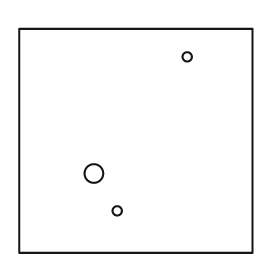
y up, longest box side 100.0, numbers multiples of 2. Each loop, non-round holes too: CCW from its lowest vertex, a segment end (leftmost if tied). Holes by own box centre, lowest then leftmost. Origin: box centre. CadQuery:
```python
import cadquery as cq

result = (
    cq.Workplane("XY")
    .moveTo(-50.0, -48.0)
    .lineTo(50.0, -48.0)
    .lineTo(50.0, 48.0)
    .lineTo(-50.0, 48.0)
    .close()
    .moveTo(-8.0, -30.0)
    .circle(2.0)
    .moveTo(-18.0, -14.0)
    .circle(4.0)
    .moveTo(22.0, 36.0)
    .circle(2.0)
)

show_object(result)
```